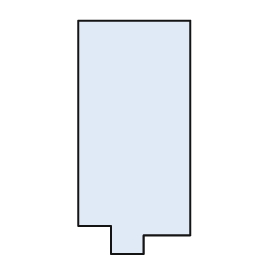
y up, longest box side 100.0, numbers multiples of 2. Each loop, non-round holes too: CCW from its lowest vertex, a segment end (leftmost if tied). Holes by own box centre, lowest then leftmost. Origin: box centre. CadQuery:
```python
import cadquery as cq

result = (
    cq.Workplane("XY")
    .moveTo(-10.0, -50.0)
    .lineTo(4.0, -50.0)
    .lineTo(4.0, -42.0)
    .lineTo(24.0, -42.0)
    .lineTo(24.0, 50.0)
    .lineTo(-24.0, 50.0)
    .lineTo(-24.0, -38.0)
    .lineTo(-10.0, -38.0)
    .close()
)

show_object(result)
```